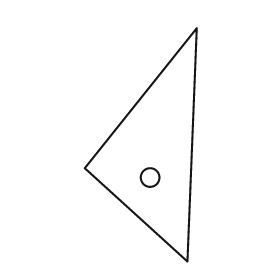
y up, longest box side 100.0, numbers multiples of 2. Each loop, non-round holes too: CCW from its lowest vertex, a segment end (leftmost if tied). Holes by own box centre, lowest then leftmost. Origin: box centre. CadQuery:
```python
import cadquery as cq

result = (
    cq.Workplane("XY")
    .moveTo(20.0, -50.0)
    .lineTo(24.0, 50.0)
    .lineTo(-24.0, -10.0)
    .close()
    .moveTo(4.0, -14.0)
    .circle(4.0)
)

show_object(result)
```